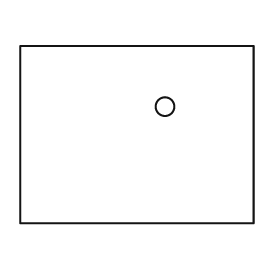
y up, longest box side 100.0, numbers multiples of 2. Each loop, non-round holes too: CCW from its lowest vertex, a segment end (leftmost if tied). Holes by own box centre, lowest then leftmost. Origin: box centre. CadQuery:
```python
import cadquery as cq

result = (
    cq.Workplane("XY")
    .moveTo(-50.0, -38.0)
    .lineTo(50.0, -38.0)
    .lineTo(50.0, 38.0)
    .lineTo(-50.0, 38.0)
    .close()
    .moveTo(12.0, 12.0)
    .circle(4.0)
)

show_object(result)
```